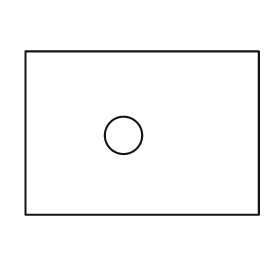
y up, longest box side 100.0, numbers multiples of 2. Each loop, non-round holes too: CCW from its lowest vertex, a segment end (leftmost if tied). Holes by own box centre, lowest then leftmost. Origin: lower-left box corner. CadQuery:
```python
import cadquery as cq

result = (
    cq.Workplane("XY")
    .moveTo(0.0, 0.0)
    .lineTo(100.0, 0.0)
    .lineTo(100.0, 70.0)
    .lineTo(0.0, 70.0)
    .close()
    .moveTo(42.0, 34.0)
    .circle(8.0)
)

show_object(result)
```